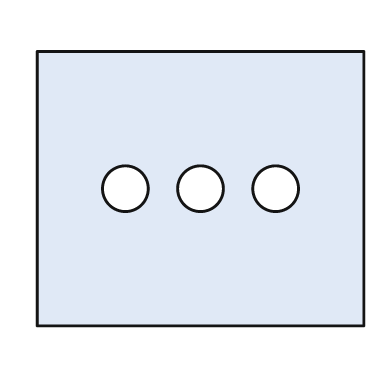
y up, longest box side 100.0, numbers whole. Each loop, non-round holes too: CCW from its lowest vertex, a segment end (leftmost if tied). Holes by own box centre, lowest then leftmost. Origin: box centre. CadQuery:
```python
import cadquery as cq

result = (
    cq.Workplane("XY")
    .moveTo(-50.0, -42.0)
    .lineTo(50.0, -42.0)
    .lineTo(50.0, 42.0)
    .lineTo(-50.0, 42.0)
    .close()
    .moveTo(-23.0, 0.0)
    .circle(7.0)
    .moveTo(0.0, 0.0)
    .circle(7.0)
    .moveTo(23.0, 0.0)
    .circle(7.0)
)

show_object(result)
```